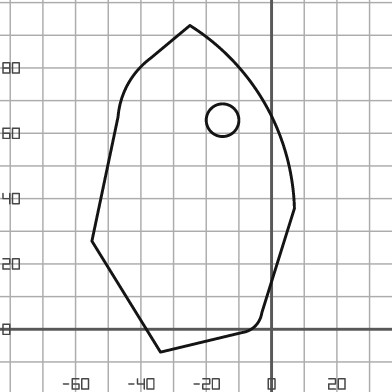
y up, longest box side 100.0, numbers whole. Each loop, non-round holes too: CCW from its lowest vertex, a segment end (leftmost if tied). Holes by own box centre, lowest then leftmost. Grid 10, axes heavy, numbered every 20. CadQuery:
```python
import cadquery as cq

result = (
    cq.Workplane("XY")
    .moveTo(-34.0, -7.0)
    .lineTo(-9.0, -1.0)
    .threePointArc((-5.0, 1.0), (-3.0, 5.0))
    .lineTo(7.0, 37.0)
    .threePointArc((-2.0, 69.0), (-25.0, 93.0))
    .lineTo(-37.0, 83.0)
    .threePointArc((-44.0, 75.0), (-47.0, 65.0))
    .lineTo(-55.0, 27.0)
    .close()
    .moveTo(-15.0, 64.0)
    .circle(5.0)
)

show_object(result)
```